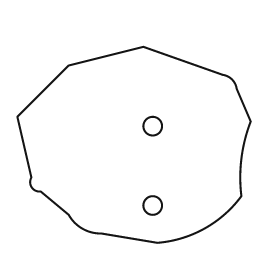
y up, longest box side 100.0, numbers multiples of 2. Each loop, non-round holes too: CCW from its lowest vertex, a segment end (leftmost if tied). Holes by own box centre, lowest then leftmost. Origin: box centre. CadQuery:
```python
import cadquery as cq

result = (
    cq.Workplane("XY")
    .moveTo(10.0, -42.0)
    .threePointArc((30.0, -36.0), (46.0, -22.0))
    .threePointArc((46.0, -6.0), (50.0, 10.0))
    .lineTo(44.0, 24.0)
    .threePointArc((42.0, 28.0), (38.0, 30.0))
    .lineTo(4.0, 42.0)
    .lineTo(-28.0, 34.0)
    .lineTo(-50.0, 12.0)
    .lineTo(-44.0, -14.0)
    .threePointArc((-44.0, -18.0), (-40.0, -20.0))
    .lineTo(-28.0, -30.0)
    .threePointArc((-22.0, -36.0), (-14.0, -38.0))
    .close()
    .moveTo(8.0, -26.0)
    .circle(4.0)
    .moveTo(8.0, 8.0)
    .circle(4.0)
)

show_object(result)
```